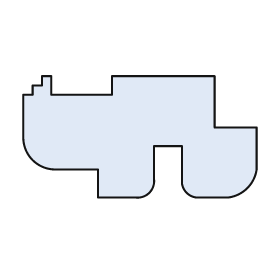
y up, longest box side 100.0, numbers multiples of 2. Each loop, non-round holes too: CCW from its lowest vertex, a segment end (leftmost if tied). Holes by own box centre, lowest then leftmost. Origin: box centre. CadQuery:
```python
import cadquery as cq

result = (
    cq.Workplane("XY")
    .moveTo(-18.0, -26.0)
    .lineTo(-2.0, -26.0)
    .threePointArc((4.0, -24.0), (6.0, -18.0))
    .lineTo(6.0, -4.0)
    .lineTo(18.0, -4.0)
    .lineTo(18.0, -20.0)
    .threePointArc((20.0, -24.0), (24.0, -26.0))
    .lineTo(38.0, -26.0)
    .threePointArc((46.0, -22.0), (50.0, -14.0))
    .lineTo(50.0, 4.0)
    .lineTo(32.0, 4.0)
    .lineTo(32.0, 26.0)
    .lineTo(-12.0, 26.0)
    .lineTo(-12.0, 18.0)
    .lineTo(-38.0, 18.0)
    .lineTo(-38.0, 26.0)
    .lineTo(-42.0, 26.0)
    .lineTo(-42.0, 22.0)
    .lineTo(-46.0, 22.0)
    .lineTo(-46.0, 18.0)
    .lineTo(-50.0, 18.0)
    .lineTo(-50.0, 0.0)
    .threePointArc((-46.0, -10.0), (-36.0, -14.0))
    .lineTo(-18.0, -14.0)
    .close()
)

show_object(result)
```